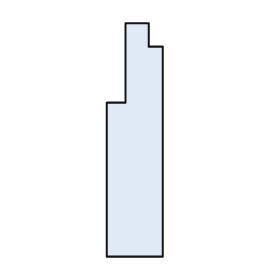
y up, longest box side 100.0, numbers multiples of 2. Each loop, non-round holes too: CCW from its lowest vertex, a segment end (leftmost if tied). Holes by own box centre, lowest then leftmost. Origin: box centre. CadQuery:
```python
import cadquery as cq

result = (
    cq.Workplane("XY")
    .moveTo(-12.0, -50.0)
    .lineTo(12.0, -50.0)
    .lineTo(12.0, 40.0)
    .lineTo(6.0, 40.0)
    .lineTo(6.0, 50.0)
    .lineTo(-4.0, 50.0)
    .lineTo(-4.0, 16.0)
    .lineTo(-12.0, 16.0)
    .close()
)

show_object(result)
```